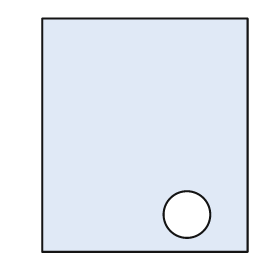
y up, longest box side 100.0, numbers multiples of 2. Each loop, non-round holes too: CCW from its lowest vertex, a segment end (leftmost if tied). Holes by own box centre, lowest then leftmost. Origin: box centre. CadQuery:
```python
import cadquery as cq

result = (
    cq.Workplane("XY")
    .moveTo(-44.0, -50.0)
    .lineTo(44.0, -50.0)
    .lineTo(44.0, 50.0)
    .lineTo(-44.0, 50.0)
    .close()
    .moveTo(18.0, -34.0)
    .circle(10.0)
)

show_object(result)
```